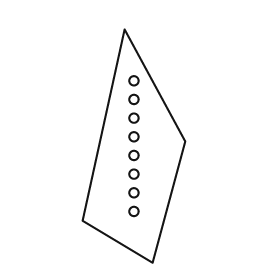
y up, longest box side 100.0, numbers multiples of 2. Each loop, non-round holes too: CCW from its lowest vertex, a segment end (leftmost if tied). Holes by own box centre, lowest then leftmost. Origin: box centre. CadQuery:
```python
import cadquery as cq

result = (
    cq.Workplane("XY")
    .moveTo(8.0, -50.0)
    .lineTo(22.0, 2.0)
    .lineTo(-4.0, 50.0)
    .lineTo(-22.0, -32.0)
    .close()
    .moveTo(0.0, -28.0)
    .circle(2.0)
    .moveTo(0.0, -20.0)
    .circle(2.0)
    .moveTo(0.0, -12.0)
    .circle(2.0)
    .moveTo(0.0, -4.0)
    .circle(2.0)
    .moveTo(0.0, 4.0)
    .circle(2.0)
    .moveTo(0.0, 12.0)
    .circle(2.0)
    .moveTo(0.0, 20.0)
    .circle(2.0)
    .moveTo(0.0, 28.0)
    .circle(2.0)
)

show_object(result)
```